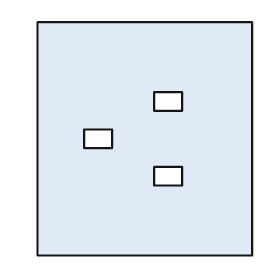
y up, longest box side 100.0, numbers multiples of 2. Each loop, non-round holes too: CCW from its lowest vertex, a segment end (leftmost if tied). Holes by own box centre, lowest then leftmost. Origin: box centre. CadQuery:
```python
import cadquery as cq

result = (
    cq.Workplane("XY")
    .moveTo(-46.0, -50.0)
    .lineTo(46.0, -50.0)
    .lineTo(46.0, 50.0)
    .lineTo(-46.0, 50.0)
    .close()
    .moveTo(4.0, -20.0)
    .lineTo(16.0, -20.0)
    .lineTo(16.0, -12.0)
    .lineTo(4.0, -12.0)
    .close()
    .moveTo(-26.0, -4.0)
    .lineTo(-14.0, -4.0)
    .lineTo(-14.0, 4.0)
    .lineTo(-26.0, 4.0)
    .close()
    .moveTo(4.0, 12.0)
    .lineTo(16.0, 12.0)
    .lineTo(16.0, 20.0)
    .lineTo(4.0, 20.0)
    .close()
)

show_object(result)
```